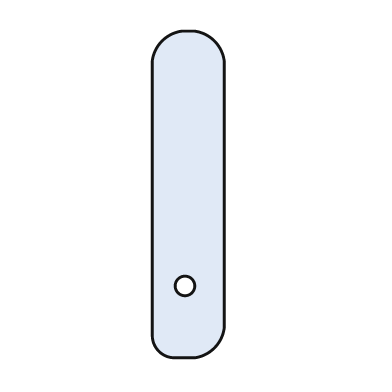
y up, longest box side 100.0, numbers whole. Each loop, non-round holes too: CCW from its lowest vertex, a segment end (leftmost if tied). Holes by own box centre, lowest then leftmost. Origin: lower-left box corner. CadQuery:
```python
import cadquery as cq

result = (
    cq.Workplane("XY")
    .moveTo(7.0, 0.0)
    .lineTo(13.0, 0.0)
    .threePointArc((19.0, 3.0), (22.0, 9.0))
    .lineTo(22.0, 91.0)
    .threePointArc((19.0, 97.0), (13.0, 100.0))
    .lineTo(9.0, 100.0)
    .threePointArc((3.0, 97.0), (0.0, 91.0))
    .lineTo(0.0, 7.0)
    .threePointArc((2.0, 2.0), (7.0, 0.0))
    .close()
    .moveTo(10.0, 22.0)
    .circle(3.0)
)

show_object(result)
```